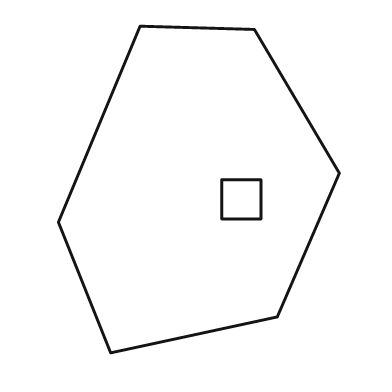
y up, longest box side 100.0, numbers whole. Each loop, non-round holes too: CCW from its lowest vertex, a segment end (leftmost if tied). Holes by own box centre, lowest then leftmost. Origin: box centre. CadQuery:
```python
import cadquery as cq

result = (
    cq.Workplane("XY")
    .moveTo(-27.0, -50.0)
    .lineTo(24.0, -39.0)
    .lineTo(43.0, 5.0)
    .lineTo(17.0, 49.0)
    .lineTo(-18.0, 50.0)
    .lineTo(-43.0, -10.0)
    .close()
    .moveTo(7.0, -9.0)
    .lineTo(19.0, -9.0)
    .lineTo(19.0, 3.0)
    .lineTo(7.0, 3.0)
    .close()
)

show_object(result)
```